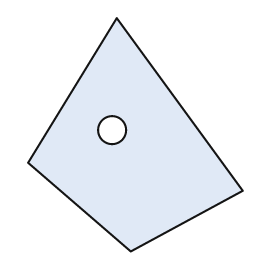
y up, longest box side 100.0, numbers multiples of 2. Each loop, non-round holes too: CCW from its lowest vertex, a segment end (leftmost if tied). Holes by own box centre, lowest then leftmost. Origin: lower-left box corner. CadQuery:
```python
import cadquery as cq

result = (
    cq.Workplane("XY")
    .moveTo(44.0, 0.0)
    .lineTo(92.0, 26.0)
    .lineTo(38.0, 100.0)
    .lineTo(0.0, 38.0)
    .close()
    .moveTo(36.0, 52.0)
    .circle(6.0)
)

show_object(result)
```